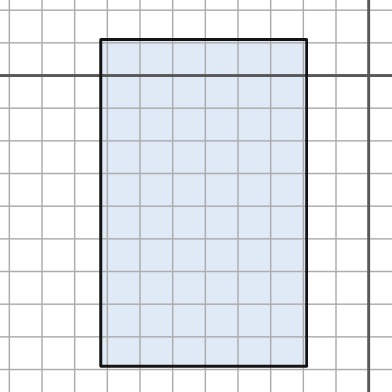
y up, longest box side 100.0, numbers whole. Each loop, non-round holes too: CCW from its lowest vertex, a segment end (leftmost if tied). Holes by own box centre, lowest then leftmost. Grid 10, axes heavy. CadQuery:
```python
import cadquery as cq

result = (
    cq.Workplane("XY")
    .moveTo(-82.0, -89.0)
    .lineTo(-19.0, -89.0)
    .lineTo(-19.0, 11.0)
    .lineTo(-82.0, 11.0)
    .close()
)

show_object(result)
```